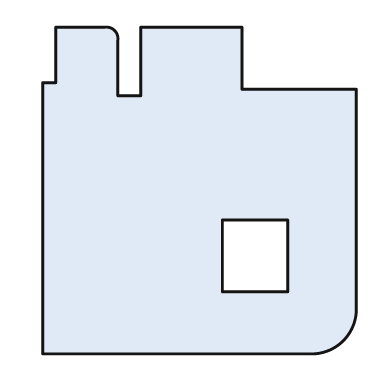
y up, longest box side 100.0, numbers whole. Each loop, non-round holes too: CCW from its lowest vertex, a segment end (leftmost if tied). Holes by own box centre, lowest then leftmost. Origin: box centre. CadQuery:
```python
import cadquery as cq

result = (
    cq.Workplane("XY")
    .moveTo(-48.0, -50.0)
    .lineTo(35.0, -50.0)
    .threePointArc((44.0, -46.0), (48.0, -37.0))
    .lineTo(48.0, 31.0)
    .lineTo(13.0, 31.0)
    .lineTo(13.0, 50.0)
    .lineTo(-18.0, 50.0)
    .lineTo(-18.0, 29.0)
    .lineTo(-25.0, 29.0)
    .lineTo(-25.0, 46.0)
    .threePointArc((-26.0, 49.0), (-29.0, 50.0))
    .lineTo(-44.0, 50.0)
    .lineTo(-44.0, 33.0)
    .lineTo(-48.0, 33.0)
    .close()
    .moveTo(7.0, -31.0)
    .lineTo(27.0, -31.0)
    .lineTo(27.0, -9.0)
    .lineTo(7.0, -9.0)
    .close()
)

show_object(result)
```